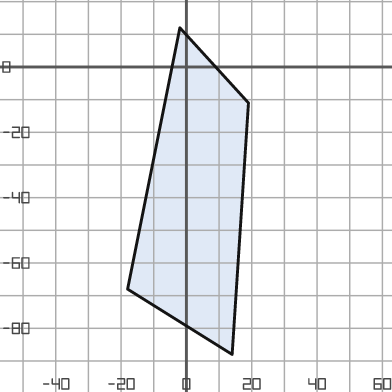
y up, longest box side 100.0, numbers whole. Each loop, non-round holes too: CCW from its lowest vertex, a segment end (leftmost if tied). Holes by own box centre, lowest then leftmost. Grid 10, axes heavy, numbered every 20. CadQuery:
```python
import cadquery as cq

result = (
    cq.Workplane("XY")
    .moveTo(14.0, -88.0)
    .lineTo(19.0, -11.0)
    .lineTo(-2.0, 12.0)
    .lineTo(-18.0, -68.0)
    .close()
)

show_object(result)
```